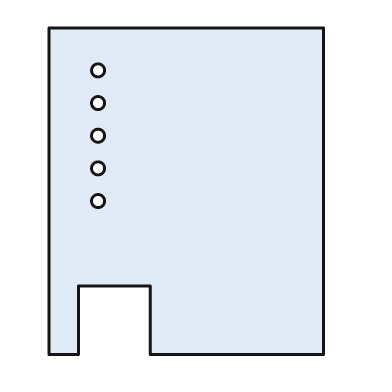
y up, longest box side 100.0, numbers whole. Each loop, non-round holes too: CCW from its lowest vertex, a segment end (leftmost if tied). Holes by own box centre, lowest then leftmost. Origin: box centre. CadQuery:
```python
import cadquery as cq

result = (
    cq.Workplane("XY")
    .moveTo(-42.0, -50.0)
    .lineTo(-33.0, -50.0)
    .lineTo(-33.0, -29.0)
    .lineTo(-11.0, -29.0)
    .lineTo(-11.0, -50.0)
    .lineTo(42.0, -50.0)
    .lineTo(42.0, 50.0)
    .lineTo(-42.0, 50.0)
    .close()
    .moveTo(-27.0, -3.0)
    .circle(2.0)
    .moveTo(-27.0, 7.0)
    .circle(2.0)
    .moveTo(-27.0, 17.0)
    .circle(2.0)
    .moveTo(-27.0, 27.0)
    .circle(2.0)
    .moveTo(-27.0, 37.0)
    .circle(2.0)
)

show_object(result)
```